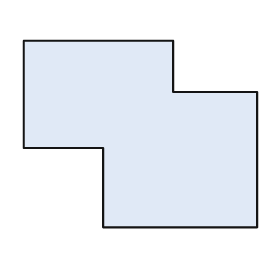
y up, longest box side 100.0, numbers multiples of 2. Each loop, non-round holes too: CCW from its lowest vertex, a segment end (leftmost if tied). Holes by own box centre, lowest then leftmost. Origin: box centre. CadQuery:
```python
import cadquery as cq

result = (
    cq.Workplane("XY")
    .moveTo(-16.0, -40.0)
    .lineTo(50.0, -40.0)
    .lineTo(50.0, 18.0)
    .lineTo(14.0, 18.0)
    .lineTo(14.0, 40.0)
    .lineTo(-50.0, 40.0)
    .lineTo(-50.0, -6.0)
    .lineTo(-16.0, -6.0)
    .close()
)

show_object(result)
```